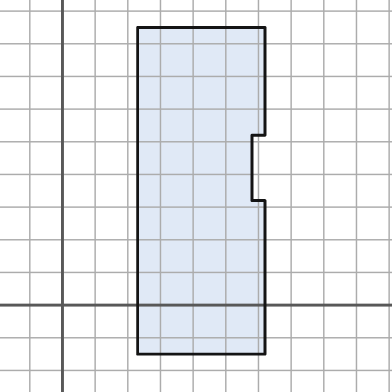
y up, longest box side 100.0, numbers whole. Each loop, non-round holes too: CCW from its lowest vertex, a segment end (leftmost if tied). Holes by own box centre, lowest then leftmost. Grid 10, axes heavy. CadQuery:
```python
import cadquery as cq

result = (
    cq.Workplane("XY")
    .moveTo(23.0, -15.0)
    .lineTo(62.0, -15.0)
    .lineTo(62.0, 32.0)
    .lineTo(58.0, 32.0)
    .lineTo(58.0, 52.0)
    .lineTo(62.0, 52.0)
    .lineTo(62.0, 85.0)
    .lineTo(23.0, 85.0)
    .close()
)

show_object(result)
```